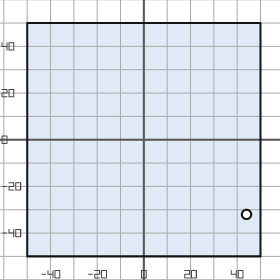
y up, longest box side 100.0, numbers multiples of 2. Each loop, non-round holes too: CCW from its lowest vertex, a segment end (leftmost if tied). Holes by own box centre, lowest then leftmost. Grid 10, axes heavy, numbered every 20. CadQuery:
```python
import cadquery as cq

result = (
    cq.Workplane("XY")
    .moveTo(-50.0, -50.0)
    .lineTo(50.0, -50.0)
    .lineTo(50.0, 50.0)
    .lineTo(-50.0, 50.0)
    .close()
    .moveTo(44.0, -32.0)
    .circle(2.0)
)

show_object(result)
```